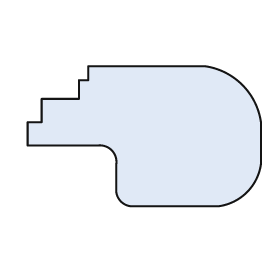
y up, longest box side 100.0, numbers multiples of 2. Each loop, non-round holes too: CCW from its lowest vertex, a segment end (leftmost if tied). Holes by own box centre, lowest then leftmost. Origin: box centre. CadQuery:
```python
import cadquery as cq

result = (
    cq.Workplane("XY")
    .moveTo(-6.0, -30.0)
    .lineTo(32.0, -30.0)
    .threePointArc((44.0, -24.0), (50.0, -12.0))
    .lineTo(50.0, 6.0)
    .threePointArc((42.0, 22.0), (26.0, 30.0))
    .lineTo(-24.0, 30.0)
    .lineTo(-24.0, 24.0)
    .lineTo(-28.0, 24.0)
    .lineTo(-28.0, 16.0)
    .lineTo(-44.0, 16.0)
    .lineTo(-44.0, 6.0)
    .lineTo(-50.0, 6.0)
    .lineTo(-50.0, -4.0)
    .lineTo(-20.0, -4.0)
    .threePointArc((-14.0, -6.0), (-12.0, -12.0))
    .lineTo(-12.0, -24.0)
    .threePointArc((-10.0, -28.0), (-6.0, -30.0))
    .close()
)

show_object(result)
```